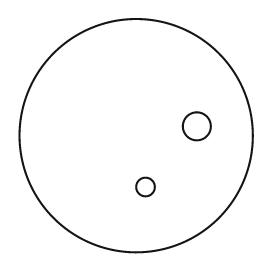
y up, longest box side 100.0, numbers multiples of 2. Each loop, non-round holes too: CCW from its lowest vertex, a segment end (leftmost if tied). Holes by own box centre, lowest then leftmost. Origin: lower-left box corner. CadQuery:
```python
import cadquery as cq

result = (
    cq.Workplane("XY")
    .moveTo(50.0, 50.0)
    .circle(50.0)
    .moveTo(54.0, 28.0)
    .circle(4.0)
    .moveTo(76.0, 54.0)
    .circle(6.0)
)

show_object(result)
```